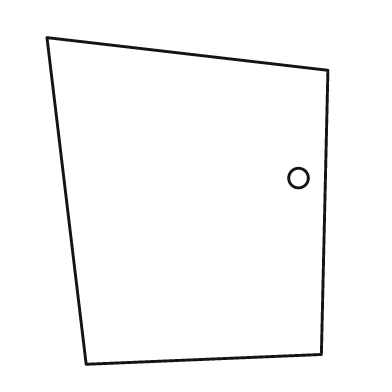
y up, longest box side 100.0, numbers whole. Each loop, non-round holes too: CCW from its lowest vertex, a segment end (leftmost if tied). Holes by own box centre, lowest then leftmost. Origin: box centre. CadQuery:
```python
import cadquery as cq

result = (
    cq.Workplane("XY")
    .moveTo(-31.0, -50.0)
    .lineTo(41.0, -47.0)
    .lineTo(43.0, 40.0)
    .lineTo(-43.0, 50.0)
    .close()
    .moveTo(34.0, 7.0)
    .circle(3.0)
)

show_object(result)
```